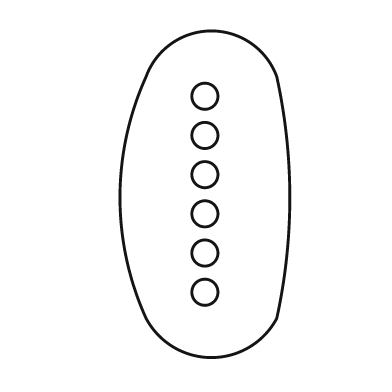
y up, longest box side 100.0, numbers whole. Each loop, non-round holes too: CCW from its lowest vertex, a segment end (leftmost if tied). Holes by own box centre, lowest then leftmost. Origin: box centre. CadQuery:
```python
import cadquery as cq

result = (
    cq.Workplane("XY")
    .moveTo(-18.0, -38.0)
    .threePointArc((2.0, -50.0), (22.0, -38.0))
    .threePointArc((26.0, -1.0), (22.0, 36.0))
    .threePointArc((2.0, 50.0), (-18.0, 36.0))
    .threePointArc((-26.0, -1.0), (-18.0, -38.0))
    .close()
    .moveTo(0.0, -30.0)
    .circle(4.0)
    .moveTo(0.0, -18.0)
    .circle(4.0)
    .moveTo(0.0, -6.0)
    .circle(4.0)
    .moveTo(0.0, 6.0)
    .circle(4.0)
    .moveTo(0.0, 18.0)
    .circle(4.0)
    .moveTo(0.0, 30.0)
    .circle(4.0)
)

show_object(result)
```